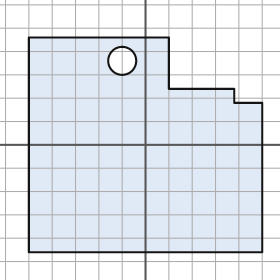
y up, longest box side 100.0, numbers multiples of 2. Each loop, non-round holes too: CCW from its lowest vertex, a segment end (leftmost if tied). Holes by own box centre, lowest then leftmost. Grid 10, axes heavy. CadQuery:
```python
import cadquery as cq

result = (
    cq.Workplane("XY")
    .moveTo(-50.0, -46.0)
    .lineTo(50.0, -46.0)
    .lineTo(50.0, 18.0)
    .lineTo(38.0, 18.0)
    .lineTo(38.0, 24.0)
    .lineTo(10.0, 24.0)
    .lineTo(10.0, 46.0)
    .lineTo(-50.0, 46.0)
    .close()
    .moveTo(-10.0, 36.0)
    .circle(6.0)
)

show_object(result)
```